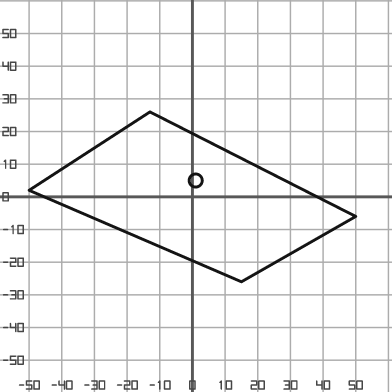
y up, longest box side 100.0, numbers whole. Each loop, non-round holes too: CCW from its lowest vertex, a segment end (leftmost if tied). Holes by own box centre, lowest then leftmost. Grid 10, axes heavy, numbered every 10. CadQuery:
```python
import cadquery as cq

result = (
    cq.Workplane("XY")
    .moveTo(15.0, -26.0)
    .lineTo(50.0, -6.0)
    .lineTo(-13.0, 26.0)
    .lineTo(-50.0, 2.0)
    .close()
    .moveTo(1.0, 5.0)
    .circle(2.0)
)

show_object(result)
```